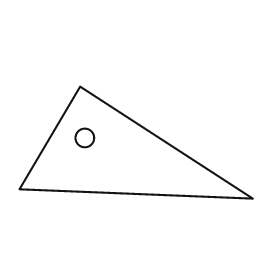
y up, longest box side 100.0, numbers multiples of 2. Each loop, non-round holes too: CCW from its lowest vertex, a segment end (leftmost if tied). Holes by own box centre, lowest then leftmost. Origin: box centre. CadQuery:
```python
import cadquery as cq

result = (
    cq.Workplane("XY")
    .moveTo(50.0, -24.0)
    .lineTo(-24.0, 24.0)
    .lineTo(-50.0, -20.0)
    .close()
    .moveTo(-22.0, 2.0)
    .circle(4.0)
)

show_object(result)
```